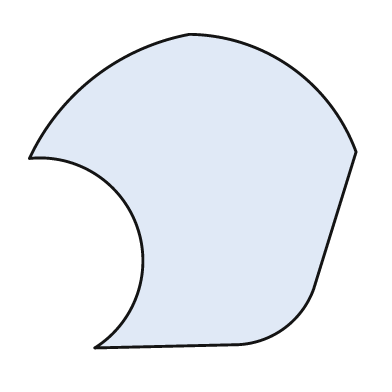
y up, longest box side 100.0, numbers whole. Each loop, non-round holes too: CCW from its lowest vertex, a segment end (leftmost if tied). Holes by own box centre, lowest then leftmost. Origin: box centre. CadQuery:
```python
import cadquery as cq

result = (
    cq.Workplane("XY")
    .moveTo(-30.0, -48.0)
    .lineTo(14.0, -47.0)
    .threePointArc((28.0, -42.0), (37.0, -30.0))
    .lineTo(50.0, 12.0)
    .threePointArc((30.0, 38.0), (-1.0, 48.0))
    .threePointArc((-30.0, 35.0), (-50.0, 10.0))
    .threePointArc((-17.0, -11.0), (-30.0, -48.0))
    .close()
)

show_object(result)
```